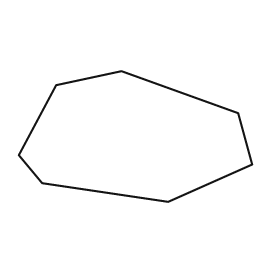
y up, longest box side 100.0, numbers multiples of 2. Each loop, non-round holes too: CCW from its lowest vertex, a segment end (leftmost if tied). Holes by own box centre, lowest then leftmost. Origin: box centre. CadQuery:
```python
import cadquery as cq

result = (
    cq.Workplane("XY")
    .moveTo(14.0, -28.0)
    .lineTo(50.0, -12.0)
    .lineTo(44.0, 10.0)
    .lineTo(-6.0, 28.0)
    .lineTo(-34.0, 22.0)
    .lineTo(-50.0, -8.0)
    .lineTo(-40.0, -20.0)
    .close()
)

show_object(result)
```